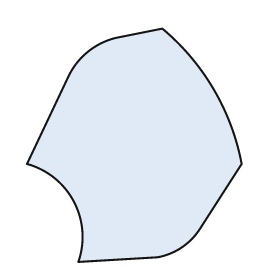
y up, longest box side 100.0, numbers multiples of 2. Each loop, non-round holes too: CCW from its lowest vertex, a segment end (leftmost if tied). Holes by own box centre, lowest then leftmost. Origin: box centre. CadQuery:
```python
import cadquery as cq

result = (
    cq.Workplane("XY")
    .moveTo(-24.0, -50.0)
    .lineTo(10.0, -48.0)
    .threePointArc((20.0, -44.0), (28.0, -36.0))
    .lineTo(46.0, -8.0)
    .threePointArc((34.0, 24.0), (12.0, 50.0))
    .lineTo(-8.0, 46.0)
    .threePointArc((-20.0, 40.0), (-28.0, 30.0))
    .lineTo(-46.0, -8.0)
    .threePointArc((-26.0, -24.0), (-24.0, -50.0))
    .close()
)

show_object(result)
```